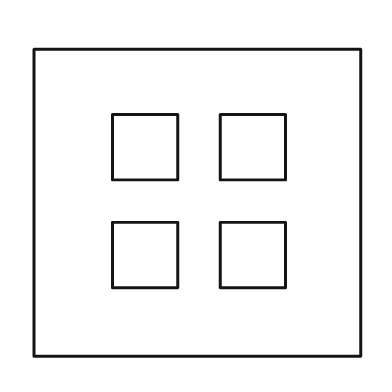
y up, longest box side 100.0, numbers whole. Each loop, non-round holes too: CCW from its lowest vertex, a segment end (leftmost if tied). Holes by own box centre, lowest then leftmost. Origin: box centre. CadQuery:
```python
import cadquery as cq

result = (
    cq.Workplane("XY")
    .moveTo(-50.0, -47.0)
    .lineTo(50.0, -47.0)
    .lineTo(50.0, 47.0)
    .lineTo(-50.0, 47.0)
    .close()
    .moveTo(-26.0, -26.0)
    .lineTo(-6.0, -26.0)
    .lineTo(-6.0, -6.0)
    .lineTo(-26.0, -6.0)
    .close()
    .moveTo(7.0, -26.0)
    .lineTo(27.0, -26.0)
    .lineTo(27.0, -6.0)
    .lineTo(7.0, -6.0)
    .close()
    .moveTo(-26.0, 7.0)
    .lineTo(-6.0, 7.0)
    .lineTo(-6.0, 27.0)
    .lineTo(-26.0, 27.0)
    .close()
    .moveTo(7.0, 7.0)
    .lineTo(27.0, 7.0)
    .lineTo(27.0, 27.0)
    .lineTo(7.0, 27.0)
    .close()
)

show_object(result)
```